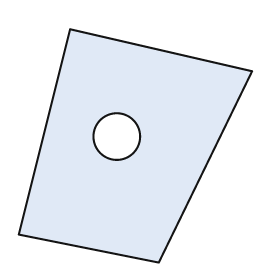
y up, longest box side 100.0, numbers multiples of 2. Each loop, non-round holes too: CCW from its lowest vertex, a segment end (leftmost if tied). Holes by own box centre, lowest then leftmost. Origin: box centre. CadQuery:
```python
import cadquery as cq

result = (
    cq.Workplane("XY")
    .moveTo(10.0, -50.0)
    .lineTo(50.0, 32.0)
    .lineTo(-28.0, 50.0)
    .lineTo(-50.0, -38.0)
    .close()
    .moveTo(-8.0, 4.0)
    .circle(10.0)
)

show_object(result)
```